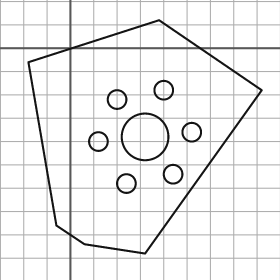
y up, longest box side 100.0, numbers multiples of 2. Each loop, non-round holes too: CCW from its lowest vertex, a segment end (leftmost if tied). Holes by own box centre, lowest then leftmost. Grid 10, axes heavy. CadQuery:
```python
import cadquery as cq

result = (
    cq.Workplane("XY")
    .moveTo(32.0, -88.0)
    .lineTo(82.0, -18.0)
    .lineTo(38.0, 12.0)
    .lineTo(-18.0, -6.0)
    .lineTo(-6.0, -76.0)
    .lineTo(6.0, -84.0)
    .close()
    .moveTo(24.0, -58.0)
    .circle(4.0)
    .moveTo(44.0, -54.0)
    .circle(4.0)
    .moveTo(12.0, -40.0)
    .circle(4.0)
    .moveTo(32.0, -38.0)
    .circle(10.0)
    .moveTo(52.0, -36.0)
    .circle(4.0)
    .moveTo(20.0, -22.0)
    .circle(4.0)
    .moveTo(40.0, -18.0)
    .circle(4.0)
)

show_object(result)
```